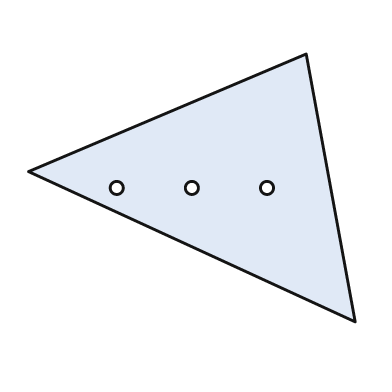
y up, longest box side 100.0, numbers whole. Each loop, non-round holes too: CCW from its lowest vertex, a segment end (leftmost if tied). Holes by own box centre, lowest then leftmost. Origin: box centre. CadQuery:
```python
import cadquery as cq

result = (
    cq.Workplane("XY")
    .moveTo(50.0, -41.0)
    .lineTo(35.0, 41.0)
    .lineTo(-50.0, 5.0)
    .close()
    .moveTo(-23.0, 0.0)
    .circle(2.0)
    .moveTo(0.0, 0.0)
    .circle(2.0)
    .moveTo(23.0, 0.0)
    .circle(2.0)
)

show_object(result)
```